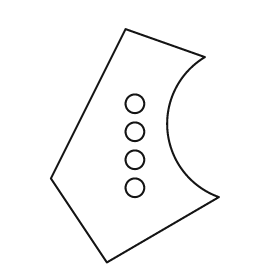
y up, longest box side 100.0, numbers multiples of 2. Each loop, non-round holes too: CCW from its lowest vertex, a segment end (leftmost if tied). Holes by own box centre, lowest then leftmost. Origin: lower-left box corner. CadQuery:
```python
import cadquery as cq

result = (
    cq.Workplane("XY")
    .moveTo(24.0, 0.0)
    .lineTo(72.0, 28.0)
    .threePointArc((50.0, 56.0), (66.0, 88.0))
    .lineTo(32.0, 100.0)
    .lineTo(0.0, 36.0)
    .close()
    .moveTo(36.0, 32.0)
    .circle(4.0)
    .moveTo(36.0, 44.0)
    .circle(4.0)
    .moveTo(36.0, 56.0)
    .circle(4.0)
    .moveTo(36.0, 68.0)
    .circle(4.0)
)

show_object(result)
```